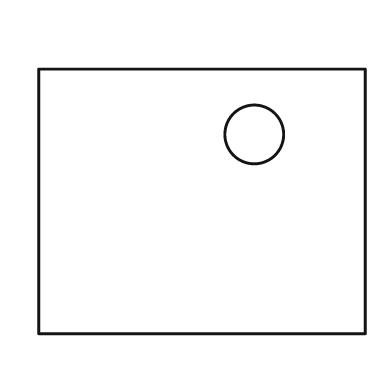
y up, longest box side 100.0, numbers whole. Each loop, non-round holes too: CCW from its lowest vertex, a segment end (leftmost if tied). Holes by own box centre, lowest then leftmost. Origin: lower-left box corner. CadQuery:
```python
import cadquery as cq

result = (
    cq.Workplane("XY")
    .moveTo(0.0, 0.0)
    .lineTo(100.0, 0.0)
    .lineTo(100.0, 81.0)
    .lineTo(0.0, 81.0)
    .close()
    .moveTo(66.0, 61.0)
    .circle(9.0)
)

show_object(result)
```